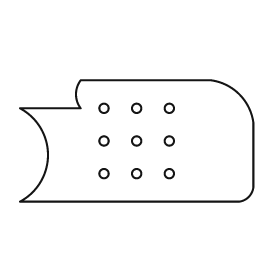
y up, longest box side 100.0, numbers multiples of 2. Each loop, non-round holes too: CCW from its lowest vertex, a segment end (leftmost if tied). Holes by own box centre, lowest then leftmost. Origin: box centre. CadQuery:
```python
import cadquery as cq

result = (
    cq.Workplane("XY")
    .moveTo(-50.0, -26.0)
    .lineTo(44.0, -26.0)
    .threePointArc((48.0, -24.0), (50.0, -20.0))
    .lineTo(50.0, 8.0)
    .threePointArc((44.0, 20.0), (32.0, 26.0))
    .lineTo(-24.0, 26.0)
    .threePointArc((-26.0, 20.0), (-24.0, 14.0))
    .lineTo(-50.0, 14.0)
    .threePointArc((-38.0, -6.0), (-50.0, -26.0))
    .close()
    .moveTo(-14.0, -14.0)
    .circle(2.0)
    .moveTo(0.0, -14.0)
    .circle(2.0)
    .moveTo(14.0, -14.0)
    .circle(2.0)
    .moveTo(-14.0, 0.0)
    .circle(2.0)
    .moveTo(0.0, 0.0)
    .circle(2.0)
    .moveTo(14.0, 0.0)
    .circle(2.0)
    .moveTo(-14.0, 14.0)
    .circle(2.0)
    .moveTo(0.0, 14.0)
    .circle(2.0)
    .moveTo(14.0, 14.0)
    .circle(2.0)
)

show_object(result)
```